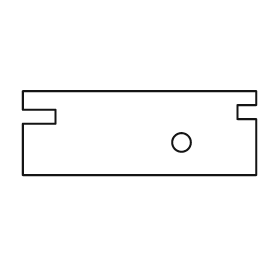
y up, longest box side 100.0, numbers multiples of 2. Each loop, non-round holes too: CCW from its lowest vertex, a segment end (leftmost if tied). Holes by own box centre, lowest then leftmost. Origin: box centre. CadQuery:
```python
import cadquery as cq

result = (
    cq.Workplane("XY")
    .moveTo(-50.0, -18.0)
    .lineTo(50.0, -18.0)
    .lineTo(50.0, 6.0)
    .lineTo(42.0, 6.0)
    .lineTo(42.0, 12.0)
    .lineTo(50.0, 12.0)
    .lineTo(50.0, 18.0)
    .lineTo(-50.0, 18.0)
    .lineTo(-50.0, 10.0)
    .lineTo(-36.0, 10.0)
    .lineTo(-36.0, 4.0)
    .lineTo(-50.0, 4.0)
    .close()
    .moveTo(18.0, -4.0)
    .circle(4.0)
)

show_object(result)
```